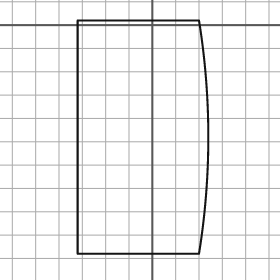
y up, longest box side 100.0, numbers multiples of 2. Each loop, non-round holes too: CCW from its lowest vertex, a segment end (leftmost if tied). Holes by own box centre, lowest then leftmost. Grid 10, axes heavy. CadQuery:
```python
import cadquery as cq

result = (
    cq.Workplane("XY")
    .moveTo(-32.0, -98.0)
    .lineTo(20.0, -98.0)
    .threePointArc((24.0, -48.0), (20.0, 2.0))
    .lineTo(-32.0, 2.0)
    .close()
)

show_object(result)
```